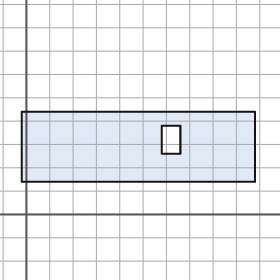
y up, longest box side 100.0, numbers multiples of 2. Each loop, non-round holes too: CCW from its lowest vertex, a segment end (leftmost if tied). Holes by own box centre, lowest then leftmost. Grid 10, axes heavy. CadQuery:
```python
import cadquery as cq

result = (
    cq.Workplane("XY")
    .moveTo(-2.0, 14.0)
    .lineTo(98.0, 14.0)
    .lineTo(98.0, 44.0)
    .lineTo(-2.0, 44.0)
    .close()
    .moveTo(58.0, 26.0)
    .lineTo(66.0, 26.0)
    .lineTo(66.0, 38.0)
    .lineTo(58.0, 38.0)
    .close()
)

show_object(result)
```